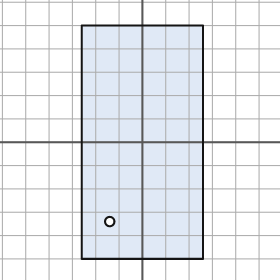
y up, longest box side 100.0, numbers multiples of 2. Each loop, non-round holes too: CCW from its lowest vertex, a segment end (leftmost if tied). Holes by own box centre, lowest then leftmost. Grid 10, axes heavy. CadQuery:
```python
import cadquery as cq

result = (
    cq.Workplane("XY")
    .moveTo(-26.0, -50.0)
    .lineTo(26.0, -50.0)
    .lineTo(26.0, 50.0)
    .lineTo(-26.0, 50.0)
    .close()
    .moveTo(-14.0, -34.0)
    .circle(2.0)
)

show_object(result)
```